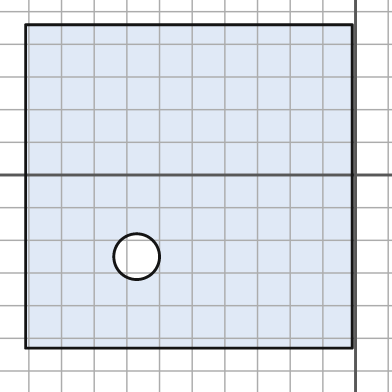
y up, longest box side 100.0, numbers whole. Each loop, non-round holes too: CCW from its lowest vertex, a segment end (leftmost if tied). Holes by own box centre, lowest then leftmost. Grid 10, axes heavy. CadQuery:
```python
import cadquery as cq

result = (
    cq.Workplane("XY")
    .moveTo(-101.0, -53.0)
    .lineTo(-1.0, -53.0)
    .lineTo(-1.0, 46.0)
    .lineTo(-101.0, 46.0)
    .close()
    .moveTo(-67.0, -25.0)
    .circle(7.0)
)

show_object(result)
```